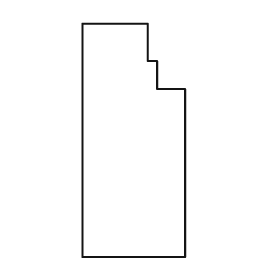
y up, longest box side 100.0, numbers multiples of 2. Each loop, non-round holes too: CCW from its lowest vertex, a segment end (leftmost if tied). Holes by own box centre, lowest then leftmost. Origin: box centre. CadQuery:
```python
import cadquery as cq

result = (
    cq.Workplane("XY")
    .moveTo(-22.0, -50.0)
    .lineTo(22.0, -50.0)
    .lineTo(22.0, 22.0)
    .lineTo(10.0, 22.0)
    .lineTo(10.0, 34.0)
    .lineTo(6.0, 34.0)
    .lineTo(6.0, 50.0)
    .lineTo(-22.0, 50.0)
    .close()
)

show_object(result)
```